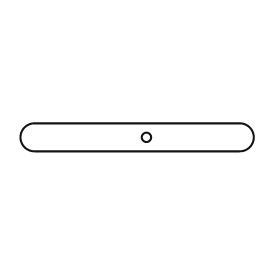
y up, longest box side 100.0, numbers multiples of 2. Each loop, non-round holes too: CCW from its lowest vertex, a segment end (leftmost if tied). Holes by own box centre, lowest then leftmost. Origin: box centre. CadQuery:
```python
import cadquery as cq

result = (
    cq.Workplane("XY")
    .moveTo(-44.0, -6.0)
    .lineTo(44.0, -6.0)
    .threePointArc((50.0, 0.0), (44.0, 6.0))
    .lineTo(-44.0, 6.0)
    .threePointArc((-50.0, 0.0), (-44.0, -6.0))
    .close()
    .moveTo(4.0, 0.0)
    .circle(2.0)
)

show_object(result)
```